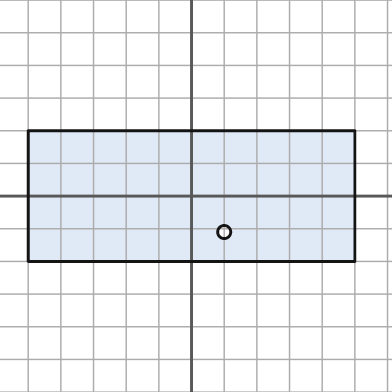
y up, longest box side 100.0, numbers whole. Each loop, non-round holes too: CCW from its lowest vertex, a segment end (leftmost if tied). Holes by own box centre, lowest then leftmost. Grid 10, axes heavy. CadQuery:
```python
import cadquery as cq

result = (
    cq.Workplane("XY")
    .moveTo(-50.0, -20.0)
    .lineTo(50.0, -20.0)
    .lineTo(50.0, 20.0)
    .lineTo(-50.0, 20.0)
    .close()
    .moveTo(10.0, -11.0)
    .circle(2.0)
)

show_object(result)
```